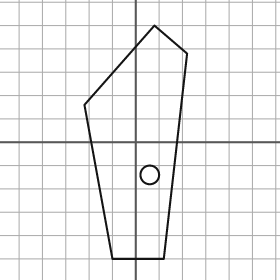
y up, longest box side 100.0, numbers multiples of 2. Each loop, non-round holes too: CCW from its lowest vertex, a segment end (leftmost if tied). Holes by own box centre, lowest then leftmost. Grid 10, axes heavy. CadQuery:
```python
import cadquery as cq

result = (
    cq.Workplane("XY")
    .moveTo(-10.0, -50.0)
    .lineTo(12.0, -50.0)
    .lineTo(22.0, 38.0)
    .lineTo(8.0, 50.0)
    .lineTo(-22.0, 16.0)
    .close()
    .moveTo(6.0, -14.0)
    .circle(4.0)
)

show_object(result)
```